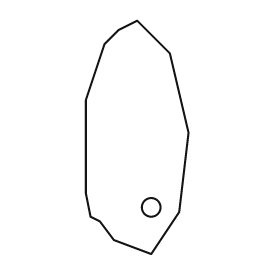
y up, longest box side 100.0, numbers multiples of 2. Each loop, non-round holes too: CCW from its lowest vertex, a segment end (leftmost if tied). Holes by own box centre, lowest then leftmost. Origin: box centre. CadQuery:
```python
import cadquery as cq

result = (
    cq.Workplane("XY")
    .moveTo(6.0, -50.0)
    .lineTo(18.0, -32.0)
    .lineTo(22.0, 2.0)
    .lineTo(14.0, 36.0)
    .lineTo(0.0, 50.0)
    .lineTo(-8.0, 46.0)
    .lineTo(-14.0, 40.0)
    .lineTo(-22.0, 16.0)
    .lineTo(-22.0, -24.0)
    .lineTo(-20.0, -34.0)
    .lineTo(-16.0, -36.0)
    .lineTo(-10.0, -44.0)
    .close()
    .moveTo(6.0, -30.0)
    .circle(4.0)
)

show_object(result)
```